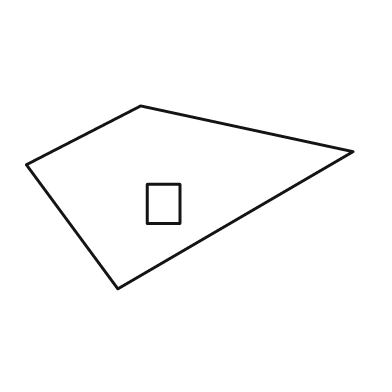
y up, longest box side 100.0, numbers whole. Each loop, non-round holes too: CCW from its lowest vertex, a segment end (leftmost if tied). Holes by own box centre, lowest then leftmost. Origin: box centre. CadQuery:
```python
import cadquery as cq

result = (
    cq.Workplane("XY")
    .moveTo(-22.0, -28.0)
    .lineTo(50.0, 14.0)
    .lineTo(-15.0, 28.0)
    .lineTo(-50.0, 10.0)
    .close()
    .moveTo(-13.0, -8.0)
    .lineTo(-3.0, -8.0)
    .lineTo(-3.0, 4.0)
    .lineTo(-13.0, 4.0)
    .close()
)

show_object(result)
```